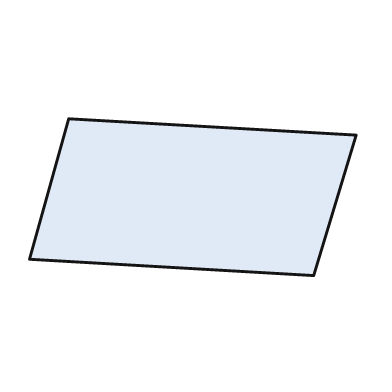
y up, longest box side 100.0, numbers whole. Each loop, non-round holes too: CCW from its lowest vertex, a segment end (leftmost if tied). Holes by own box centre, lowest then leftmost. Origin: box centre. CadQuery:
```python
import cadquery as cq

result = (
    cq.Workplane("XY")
    .moveTo(37.0, -24.0)
    .lineTo(50.0, 19.0)
    .lineTo(-38.0, 24.0)
    .lineTo(-50.0, -19.0)
    .close()
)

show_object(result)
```